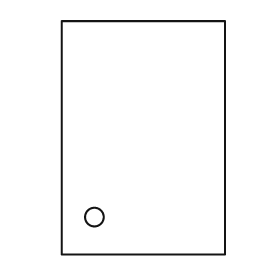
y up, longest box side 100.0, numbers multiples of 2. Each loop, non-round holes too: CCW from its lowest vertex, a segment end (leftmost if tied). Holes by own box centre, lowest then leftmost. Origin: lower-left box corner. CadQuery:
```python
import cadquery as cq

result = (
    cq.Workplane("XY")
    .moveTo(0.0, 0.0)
    .lineTo(70.0, 0.0)
    .lineTo(70.0, 100.0)
    .lineTo(0.0, 100.0)
    .close()
    .moveTo(14.0, 16.0)
    .circle(4.0)
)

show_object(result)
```